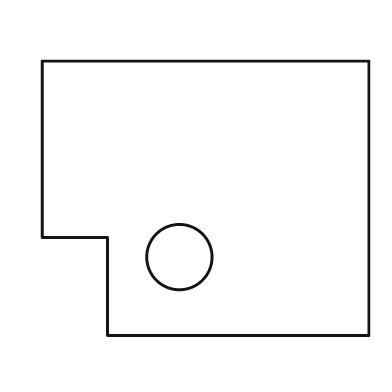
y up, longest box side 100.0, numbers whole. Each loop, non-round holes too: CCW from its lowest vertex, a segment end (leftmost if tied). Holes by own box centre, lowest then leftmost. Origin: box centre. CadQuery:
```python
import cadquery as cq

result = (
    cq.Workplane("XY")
    .moveTo(-30.0, -42.0)
    .lineTo(50.0, -42.0)
    .lineTo(50.0, 42.0)
    .lineTo(-50.0, 42.0)
    .lineTo(-50.0, -12.0)
    .lineTo(-30.0, -12.0)
    .close()
    .moveTo(-8.0, -18.0)
    .circle(10.0)
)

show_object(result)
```